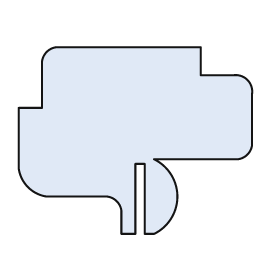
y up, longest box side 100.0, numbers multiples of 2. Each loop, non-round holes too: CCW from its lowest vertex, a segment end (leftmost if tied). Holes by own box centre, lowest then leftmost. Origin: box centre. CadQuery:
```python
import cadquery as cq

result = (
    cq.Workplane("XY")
    .moveTo(-6.0, -40.0)
    .lineTo(0.0, -40.0)
    .lineTo(0.0, -10.0)
    .lineTo(4.0, -10.0)
    .lineTo(4.0, -40.0)
    .lineTo(8.0, -40.0)
    .threePointArc((18.0, -24.0), (8.0, -8.0))
    .lineTo(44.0, -8.0)
    .threePointArc((48.0, -6.0), (50.0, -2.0))
    .lineTo(50.0, 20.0)
    .threePointArc((48.0, 26.0), (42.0, 28.0))
    .lineTo(28.0, 28.0)
    .lineTo(28.0, 40.0)
    .lineTo(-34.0, 40.0)
    .threePointArc((-38.0, 38.0), (-40.0, 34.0))
    .lineTo(-40.0, 14.0)
    .lineTo(-50.0, 14.0)
    .lineTo(-50.0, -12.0)
    .threePointArc((-46.0, -20.0), (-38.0, -24.0))
    .lineTo(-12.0, -24.0)
    .threePointArc((-8.0, -26.0), (-6.0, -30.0))
    .close()
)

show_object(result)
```